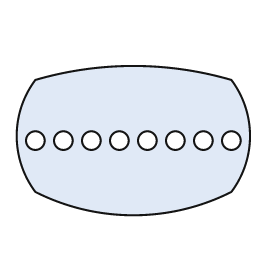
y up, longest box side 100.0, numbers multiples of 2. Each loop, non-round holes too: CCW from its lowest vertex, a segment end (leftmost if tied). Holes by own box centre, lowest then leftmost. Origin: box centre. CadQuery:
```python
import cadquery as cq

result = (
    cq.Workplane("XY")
    .moveTo(-42.0, -22.0)
    .threePointArc((0.0, -32.0), (42.0, -22.0))
    .threePointArc((50.0, 2.0), (42.0, 26.0))
    .threePointArc((0.0, 32.0), (-42.0, 26.0))
    .threePointArc((-50.0, 2.0), (-42.0, -22.0))
    .close()
    .moveTo(-42.0, 0.0)
    .circle(4.0)
    .moveTo(-30.0, 0.0)
    .circle(4.0)
    .moveTo(-18.0, 0.0)
    .circle(4.0)
    .moveTo(-6.0, 0.0)
    .circle(4.0)
    .moveTo(6.0, 0.0)
    .circle(4.0)
    .moveTo(18.0, 0.0)
    .circle(4.0)
    .moveTo(30.0, 0.0)
    .circle(4.0)
    .moveTo(42.0, 0.0)
    .circle(4.0)
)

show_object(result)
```